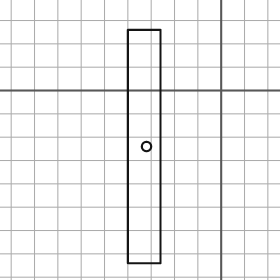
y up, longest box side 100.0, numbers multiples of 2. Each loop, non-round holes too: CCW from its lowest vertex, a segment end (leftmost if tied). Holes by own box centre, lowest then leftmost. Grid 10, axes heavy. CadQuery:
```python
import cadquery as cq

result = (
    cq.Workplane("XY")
    .moveTo(-40.0, -74.0)
    .lineTo(-26.0, -74.0)
    .lineTo(-26.0, 26.0)
    .lineTo(-40.0, 26.0)
    .close()
    .moveTo(-32.0, -24.0)
    .circle(2.0)
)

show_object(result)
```